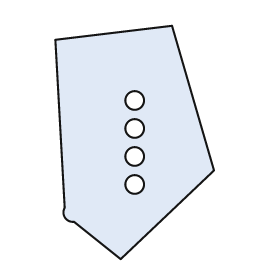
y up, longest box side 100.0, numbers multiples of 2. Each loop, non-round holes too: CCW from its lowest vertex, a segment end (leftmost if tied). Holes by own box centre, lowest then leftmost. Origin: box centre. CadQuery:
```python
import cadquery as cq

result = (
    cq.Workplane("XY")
    .moveTo(-6.0, -50.0)
    .lineTo(34.0, -12.0)
    .lineTo(16.0, 50.0)
    .lineTo(-34.0, 44.0)
    .lineTo(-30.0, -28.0)
    .threePointArc((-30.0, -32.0), (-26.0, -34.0))
    .close()
    .moveTo(0.0, -18.0)
    .circle(4.0)
    .moveTo(0.0, -6.0)
    .circle(4.0)
    .moveTo(0.0, 6.0)
    .circle(4.0)
    .moveTo(0.0, 18.0)
    .circle(4.0)
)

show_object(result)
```